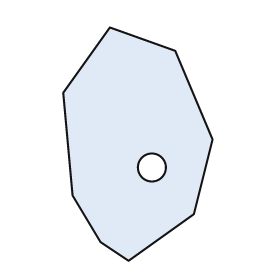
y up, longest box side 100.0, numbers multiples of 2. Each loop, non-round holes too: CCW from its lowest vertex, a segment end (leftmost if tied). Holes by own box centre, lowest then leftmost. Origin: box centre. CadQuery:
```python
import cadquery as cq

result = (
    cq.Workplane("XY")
    .moveTo(-4.0, -50.0)
    .lineTo(24.0, -30.0)
    .lineTo(32.0, 2.0)
    .lineTo(16.0, 40.0)
    .lineTo(-12.0, 50.0)
    .lineTo(-32.0, 22.0)
    .lineTo(-28.0, -22.0)
    .lineTo(-16.0, -42.0)
    .close()
    .moveTo(6.0, -10.0)
    .circle(6.0)
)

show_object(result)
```